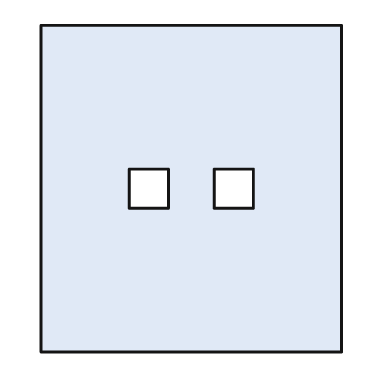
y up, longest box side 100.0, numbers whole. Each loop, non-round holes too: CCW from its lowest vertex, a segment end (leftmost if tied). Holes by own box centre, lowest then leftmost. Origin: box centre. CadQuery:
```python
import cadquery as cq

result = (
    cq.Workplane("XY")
    .moveTo(-46.0, -50.0)
    .lineTo(46.0, -50.0)
    .lineTo(46.0, 50.0)
    .lineTo(-46.0, 50.0)
    .close()
    .moveTo(-19.0, -6.0)
    .lineTo(-7.0, -6.0)
    .lineTo(-7.0, 6.0)
    .lineTo(-19.0, 6.0)
    .close()
    .moveTo(7.0, -6.0)
    .lineTo(19.0, -6.0)
    .lineTo(19.0, 6.0)
    .lineTo(7.0, 6.0)
    .close()
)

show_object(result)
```